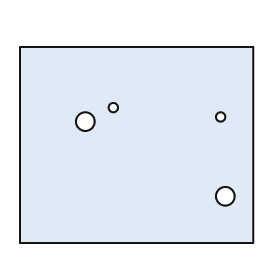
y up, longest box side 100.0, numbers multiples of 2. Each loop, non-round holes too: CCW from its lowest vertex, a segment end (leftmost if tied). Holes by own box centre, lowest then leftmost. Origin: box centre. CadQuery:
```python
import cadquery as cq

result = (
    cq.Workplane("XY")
    .moveTo(-50.0, -42.0)
    .lineTo(50.0, -42.0)
    .lineTo(50.0, 42.0)
    .lineTo(-50.0, 42.0)
    .close()
    .moveTo(38.0, -22.0)
    .circle(4.0)
    .moveTo(-22.0, 10.0)
    .circle(4.0)
    .moveTo(36.0, 12.0)
    .circle(2.0)
    .moveTo(-10.0, 16.0)
    .circle(2.0)
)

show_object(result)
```